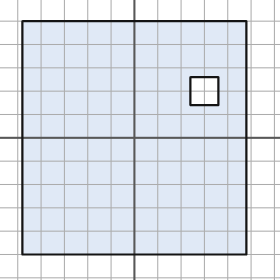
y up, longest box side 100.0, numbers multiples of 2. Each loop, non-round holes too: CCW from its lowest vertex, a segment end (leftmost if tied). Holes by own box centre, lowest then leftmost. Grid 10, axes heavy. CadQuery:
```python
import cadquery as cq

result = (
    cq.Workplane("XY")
    .moveTo(-48.0, -50.0)
    .lineTo(48.0, -50.0)
    .lineTo(48.0, 50.0)
    .lineTo(-48.0, 50.0)
    .close()
    .moveTo(24.0, 14.0)
    .lineTo(36.0, 14.0)
    .lineTo(36.0, 26.0)
    .lineTo(24.0, 26.0)
    .close()
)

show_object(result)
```